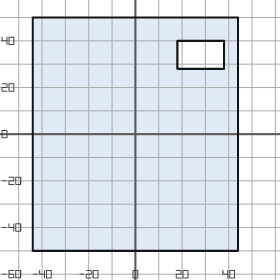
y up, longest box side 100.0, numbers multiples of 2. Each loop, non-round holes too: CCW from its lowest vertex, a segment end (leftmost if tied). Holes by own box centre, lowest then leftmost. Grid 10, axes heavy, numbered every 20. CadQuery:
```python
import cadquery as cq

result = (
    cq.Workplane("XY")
    .moveTo(-44.0, -50.0)
    .lineTo(44.0, -50.0)
    .lineTo(44.0, 50.0)
    .lineTo(-44.0, 50.0)
    .close()
    .moveTo(18.0, 28.0)
    .lineTo(38.0, 28.0)
    .lineTo(38.0, 40.0)
    .lineTo(18.0, 40.0)
    .close()
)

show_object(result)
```